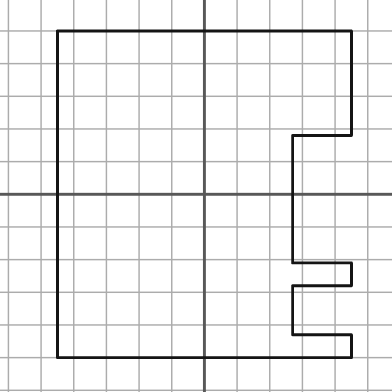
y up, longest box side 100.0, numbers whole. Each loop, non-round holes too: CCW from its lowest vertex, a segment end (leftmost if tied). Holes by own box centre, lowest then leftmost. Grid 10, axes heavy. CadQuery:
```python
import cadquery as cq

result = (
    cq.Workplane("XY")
    .moveTo(-45.0, -50.0)
    .lineTo(45.0, -50.0)
    .lineTo(45.0, -43.0)
    .lineTo(27.0, -43.0)
    .lineTo(27.0, -28.0)
    .lineTo(45.0, -28.0)
    .lineTo(45.0, -21.0)
    .lineTo(27.0, -21.0)
    .lineTo(27.0, 18.0)
    .lineTo(45.0, 18.0)
    .lineTo(45.0, 50.0)
    .lineTo(-45.0, 50.0)
    .close()
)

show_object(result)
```